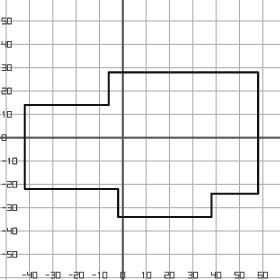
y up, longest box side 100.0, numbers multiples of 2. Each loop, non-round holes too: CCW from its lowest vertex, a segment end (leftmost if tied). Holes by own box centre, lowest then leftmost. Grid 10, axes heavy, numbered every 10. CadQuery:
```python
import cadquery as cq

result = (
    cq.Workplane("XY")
    .moveTo(-2.0, -34.0)
    .lineTo(38.0, -34.0)
    .lineTo(38.0, -24.0)
    .lineTo(58.0, -24.0)
    .lineTo(58.0, 28.0)
    .lineTo(-6.0, 28.0)
    .lineTo(-6.0, 14.0)
    .lineTo(-42.0, 14.0)
    .lineTo(-42.0, -22.0)
    .lineTo(-2.0, -22.0)
    .close()
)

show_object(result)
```